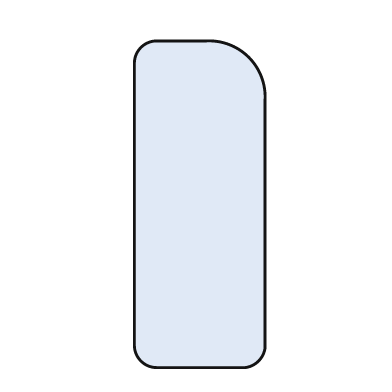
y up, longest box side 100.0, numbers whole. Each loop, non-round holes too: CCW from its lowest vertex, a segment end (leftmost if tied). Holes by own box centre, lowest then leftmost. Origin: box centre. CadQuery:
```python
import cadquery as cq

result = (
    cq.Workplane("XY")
    .moveTo(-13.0, -50.0)
    .lineTo(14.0, -50.0)
    .threePointArc((18.0, -48.0), (20.0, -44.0))
    .lineTo(20.0, 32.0)
    .threePointArc((15.0, 45.0), (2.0, 50.0))
    .lineTo(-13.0, 50.0)
    .threePointArc((-18.0, 48.0), (-20.0, 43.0))
    .lineTo(-20.0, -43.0)
    .threePointArc((-18.0, -48.0), (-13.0, -50.0))
    .close()
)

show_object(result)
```